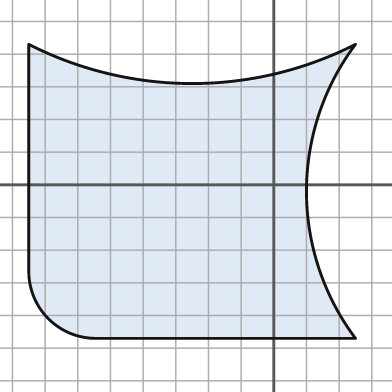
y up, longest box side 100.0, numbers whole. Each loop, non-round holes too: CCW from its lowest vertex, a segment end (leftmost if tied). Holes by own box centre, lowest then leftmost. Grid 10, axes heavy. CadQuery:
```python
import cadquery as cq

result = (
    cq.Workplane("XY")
    .moveTo(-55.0, -47.0)
    .lineTo(25.0, -47.0)
    .threePointArc((10.0, -2.0), (25.0, 43.0))
    .threePointArc((-25.0, 31.0), (-75.0, 43.0))
    .lineTo(-75.0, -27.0)
    .threePointArc((-69.0, -41.0), (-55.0, -47.0))
    .close()
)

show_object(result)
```